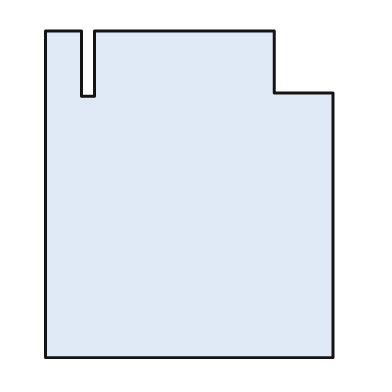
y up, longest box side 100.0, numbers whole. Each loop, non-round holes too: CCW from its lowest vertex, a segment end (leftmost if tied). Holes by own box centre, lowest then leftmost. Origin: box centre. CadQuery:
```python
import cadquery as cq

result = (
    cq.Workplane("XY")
    .moveTo(-44.0, -50.0)
    .lineTo(44.0, -50.0)
    .lineTo(44.0, 31.0)
    .lineTo(26.0, 31.0)
    .lineTo(26.0, 50.0)
    .lineTo(-29.0, 50.0)
    .lineTo(-29.0, 30.0)
    .lineTo(-33.0, 30.0)
    .lineTo(-33.0, 50.0)
    .lineTo(-44.0, 50.0)
    .close()
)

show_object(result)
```